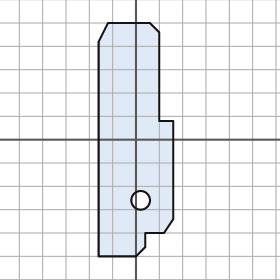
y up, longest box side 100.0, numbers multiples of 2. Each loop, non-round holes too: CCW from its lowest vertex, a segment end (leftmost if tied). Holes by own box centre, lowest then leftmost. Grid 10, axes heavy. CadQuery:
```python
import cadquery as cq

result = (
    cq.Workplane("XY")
    .moveTo(-16.0, -50.0)
    .lineTo(0.0, -50.0)
    .lineTo(4.0, -46.0)
    .lineTo(4.0, -40.0)
    .lineTo(12.0, -40.0)
    .lineTo(16.0, -34.0)
    .lineTo(16.0, 8.0)
    .lineTo(10.0, 8.0)
    .lineTo(10.0, 46.0)
    .lineTo(6.0, 50.0)
    .lineTo(-12.0, 50.0)
    .lineTo(-16.0, 42.0)
    .close()
    .moveTo(2.0, -26.0)
    .circle(4.0)
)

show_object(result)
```